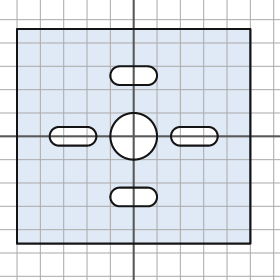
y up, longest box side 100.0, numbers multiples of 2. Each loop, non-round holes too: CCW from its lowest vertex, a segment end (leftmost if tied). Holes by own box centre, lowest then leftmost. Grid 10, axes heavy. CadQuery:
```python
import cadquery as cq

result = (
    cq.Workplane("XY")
    .moveTo(-50.0, -46.0)
    .lineTo(50.0, -46.0)
    .lineTo(50.0, 46.0)
    .lineTo(-50.0, 46.0)
    .close()
    .moveTo(-6.0, -30.0)
    .lineTo(6.0, -30.0)
    .threePointArc((10.0, -26.0), (6.0, -22.0))
    .lineTo(-6.0, -22.0)
    .threePointArc((-10.0, -26.0), (-6.0, -30.0))
    .close()
    .moveTo(-32.0, -4.0)
    .lineTo(-20.0, -4.0)
    .threePointArc((-16.0, 0.0), (-20.0, 4.0))
    .lineTo(-32.0, 4.0)
    .threePointArc((-36.0, 0.0), (-32.0, -4.0))
    .close()
    .moveTo(0.0, 0.0)
    .circle(10.0)
    .moveTo(20.0, -4.0)
    .lineTo(32.0, -4.0)
    .threePointArc((36.0, 0.0), (32.0, 4.0))
    .lineTo(20.0, 4.0)
    .threePointArc((16.0, 0.0), (20.0, -4.0))
    .close()
    .moveTo(-6.0, 22.0)
    .lineTo(6.0, 22.0)
    .threePointArc((10.0, 26.0), (6.0, 30.0))
    .lineTo(-6.0, 30.0)
    .threePointArc((-10.0, 26.0), (-6.0, 22.0))
    .close()
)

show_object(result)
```